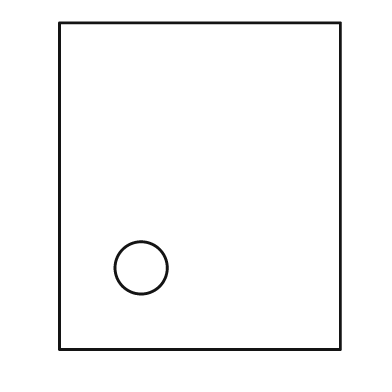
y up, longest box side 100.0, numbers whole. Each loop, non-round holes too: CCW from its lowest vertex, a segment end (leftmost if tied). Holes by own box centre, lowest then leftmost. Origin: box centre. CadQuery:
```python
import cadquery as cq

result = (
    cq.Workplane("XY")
    .moveTo(-43.0, -50.0)
    .lineTo(43.0, -50.0)
    .lineTo(43.0, 50.0)
    .lineTo(-43.0, 50.0)
    .close()
    .moveTo(-18.0, -25.0)
    .circle(8.0)
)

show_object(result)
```